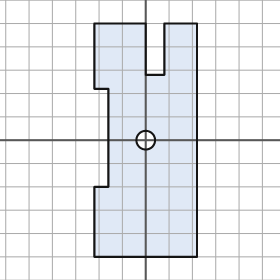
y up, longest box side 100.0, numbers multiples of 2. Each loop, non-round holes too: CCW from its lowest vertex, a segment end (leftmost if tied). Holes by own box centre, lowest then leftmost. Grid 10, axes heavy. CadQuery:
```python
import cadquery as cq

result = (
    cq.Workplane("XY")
    .moveTo(-22.0, -50.0)
    .lineTo(22.0, -50.0)
    .lineTo(22.0, 50.0)
    .lineTo(8.0, 50.0)
    .lineTo(8.0, 28.0)
    .lineTo(0.0, 28.0)
    .lineTo(0.0, 50.0)
    .lineTo(-22.0, 50.0)
    .lineTo(-22.0, 22.0)
    .lineTo(-16.0, 22.0)
    .lineTo(-16.0, -20.0)
    .lineTo(-22.0, -20.0)
    .close()
    .moveTo(0.0, 0.0)
    .circle(4.0)
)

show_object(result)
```